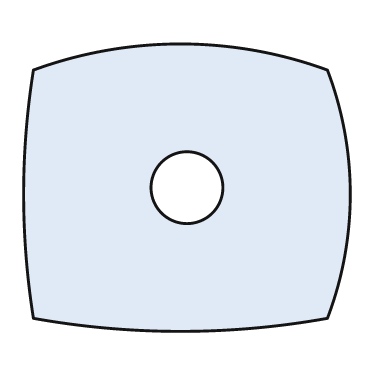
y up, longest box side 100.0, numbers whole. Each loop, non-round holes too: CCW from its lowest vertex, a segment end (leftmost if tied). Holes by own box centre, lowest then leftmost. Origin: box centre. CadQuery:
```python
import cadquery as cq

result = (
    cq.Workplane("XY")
    .moveTo(-47.0, -40.0)
    .threePointArc((-2.0, -44.0), (43.0, -40.0))
    .threePointArc((50.0, -2.0), (43.0, 36.0))
    .threePointArc((-2.0, 44.0), (-47.0, 36.0))
    .threePointArc((-50.0, -2.0), (-47.0, -40.0))
    .close()
    .moveTo(0.0, 0.0)
    .circle(11.0)
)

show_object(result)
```